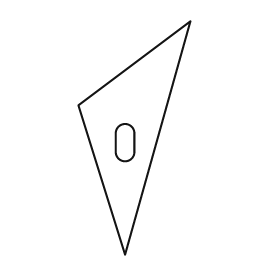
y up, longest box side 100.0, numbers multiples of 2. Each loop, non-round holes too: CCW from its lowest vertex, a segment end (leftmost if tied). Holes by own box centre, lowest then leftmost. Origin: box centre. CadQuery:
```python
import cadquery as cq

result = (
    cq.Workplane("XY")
    .moveTo(-4.0, -50.0)
    .lineTo(24.0, 50.0)
    .lineTo(-24.0, 14.0)
    .close()
    .moveTo(-8.0, -6.0)
    .threePointArc((-4.0, -10.0), (0.0, -6.0))
    .lineTo(0.0, 2.0)
    .threePointArc((-4.0, 6.0), (-8.0, 2.0))
    .close()
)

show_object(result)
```